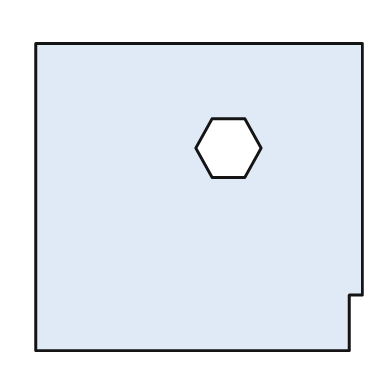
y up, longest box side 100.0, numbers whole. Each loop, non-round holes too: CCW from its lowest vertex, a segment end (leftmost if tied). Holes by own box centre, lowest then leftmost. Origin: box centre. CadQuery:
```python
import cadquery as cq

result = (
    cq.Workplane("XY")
    .moveTo(-50.0, -47.0)
    .lineTo(46.0, -47.0)
    .lineTo(46.0, -30.0)
    .lineTo(50.0, -30.0)
    .lineTo(50.0, 47.0)
    .lineTo(-50.0, 47.0)
    .close()
    .moveTo(4.0, 6.0)
    .lineTo(14.0, 6.0)
    .lineTo(19.0, 15.0)
    .lineTo(14.0, 24.0)
    .lineTo(4.0, 24.0)
    .lineTo(-1.0, 15.0)
    .close()
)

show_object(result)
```